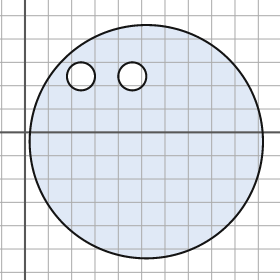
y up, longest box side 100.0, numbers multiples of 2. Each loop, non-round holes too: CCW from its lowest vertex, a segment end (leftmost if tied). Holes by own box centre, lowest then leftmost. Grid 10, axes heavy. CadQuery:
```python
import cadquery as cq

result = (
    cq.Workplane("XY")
    .moveTo(52.0, -4.0)
    .circle(50.0)
    .moveTo(24.0, 24.0)
    .circle(6.0)
    .moveTo(46.0, 24.0)
    .circle(6.0)
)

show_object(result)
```